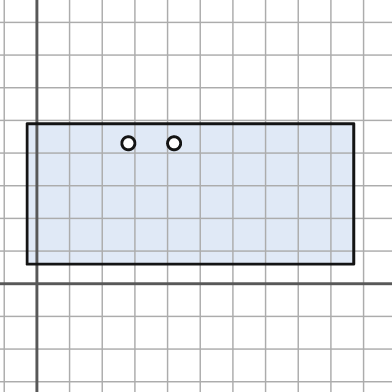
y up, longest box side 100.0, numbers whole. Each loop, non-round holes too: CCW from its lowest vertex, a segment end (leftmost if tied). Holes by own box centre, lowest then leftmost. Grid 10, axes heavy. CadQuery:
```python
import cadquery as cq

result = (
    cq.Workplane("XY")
    .moveTo(-3.0, 6.0)
    .lineTo(97.0, 6.0)
    .lineTo(97.0, 49.0)
    .lineTo(-3.0, 49.0)
    .close()
    .moveTo(28.0, 43.0)
    .circle(2.0)
    .moveTo(42.0, 43.0)
    .circle(2.0)
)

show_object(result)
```